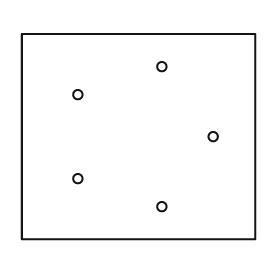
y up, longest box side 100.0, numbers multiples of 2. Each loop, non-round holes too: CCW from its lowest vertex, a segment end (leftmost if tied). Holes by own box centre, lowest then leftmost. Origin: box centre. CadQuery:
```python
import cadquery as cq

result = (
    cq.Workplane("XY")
    .moveTo(-50.0, -44.0)
    .lineTo(50.0, -44.0)
    .lineTo(50.0, 44.0)
    .lineTo(-50.0, 44.0)
    .close()
    .moveTo(10.0, -30.0)
    .circle(2.0)
    .moveTo(-26.0, -18.0)
    .circle(2.0)
    .moveTo(32.0, 0.0)
    .circle(2.0)
    .moveTo(-26.0, 18.0)
    .circle(2.0)
    .moveTo(10.0, 30.0)
    .circle(2.0)
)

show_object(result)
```